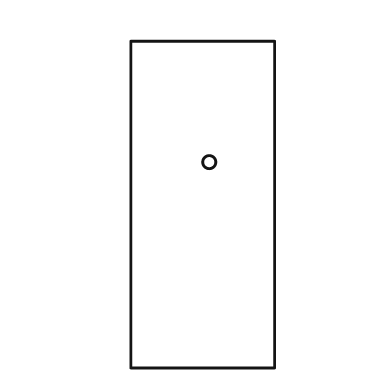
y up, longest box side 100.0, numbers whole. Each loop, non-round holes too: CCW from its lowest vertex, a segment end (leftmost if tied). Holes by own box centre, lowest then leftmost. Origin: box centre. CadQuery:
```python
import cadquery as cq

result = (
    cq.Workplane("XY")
    .moveTo(-22.0, -50.0)
    .lineTo(22.0, -50.0)
    .lineTo(22.0, 50.0)
    .lineTo(-22.0, 50.0)
    .close()
    .moveTo(2.0, 13.0)
    .circle(2.0)
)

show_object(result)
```